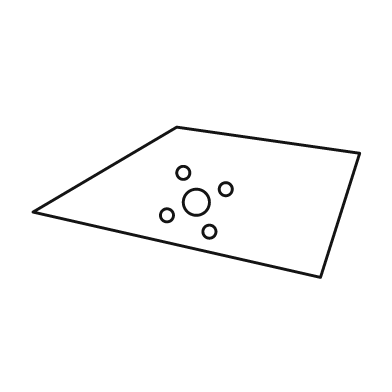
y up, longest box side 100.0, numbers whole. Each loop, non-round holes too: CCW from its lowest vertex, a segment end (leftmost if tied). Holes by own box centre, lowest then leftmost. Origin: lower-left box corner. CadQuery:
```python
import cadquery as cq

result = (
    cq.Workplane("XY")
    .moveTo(88.0, 0.0)
    .lineTo(100.0, 38.0)
    .lineTo(44.0, 46.0)
    .lineTo(0.0, 20.0)
    .close()
    .moveTo(54.0, 14.0)
    .circle(2.0)
    .moveTo(41.0, 19.0)
    .circle(2.0)
    .moveTo(50.0, 23.0)
    .circle(4.0)
    .moveTo(59.0, 27.0)
    .circle(2.0)
    .moveTo(46.0, 32.0)
    .circle(2.0)
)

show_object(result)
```